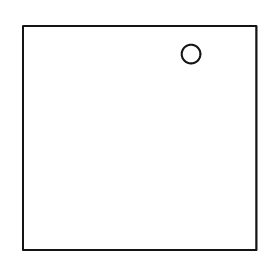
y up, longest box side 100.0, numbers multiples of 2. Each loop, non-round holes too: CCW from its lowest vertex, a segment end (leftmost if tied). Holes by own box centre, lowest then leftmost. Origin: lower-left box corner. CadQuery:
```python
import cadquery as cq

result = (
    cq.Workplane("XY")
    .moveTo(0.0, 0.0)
    .lineTo(100.0, 0.0)
    .lineTo(100.0, 96.0)
    .lineTo(0.0, 96.0)
    .close()
    .moveTo(72.0, 84.0)
    .circle(4.0)
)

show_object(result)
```